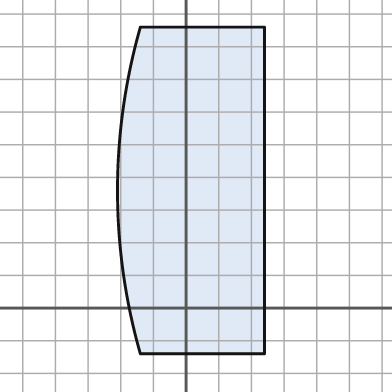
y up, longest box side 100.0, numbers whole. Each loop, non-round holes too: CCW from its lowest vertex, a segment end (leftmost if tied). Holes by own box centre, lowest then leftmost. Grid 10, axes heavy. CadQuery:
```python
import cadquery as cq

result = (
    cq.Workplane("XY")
    .moveTo(-14.0, -14.0)
    .lineTo(24.0, -14.0)
    .lineTo(24.0, 86.0)
    .lineTo(-14.0, 86.0)
    .threePointArc((-21.0, 36.0), (-14.0, -14.0))
    .close()
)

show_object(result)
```